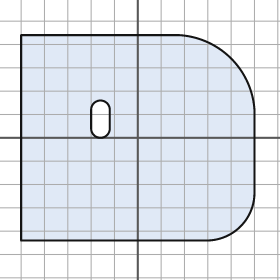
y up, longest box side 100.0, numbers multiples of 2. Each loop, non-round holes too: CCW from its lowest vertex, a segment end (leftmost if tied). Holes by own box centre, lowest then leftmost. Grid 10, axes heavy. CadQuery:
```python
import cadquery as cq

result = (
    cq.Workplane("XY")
    .moveTo(-50.0, -44.0)
    .lineTo(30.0, -44.0)
    .threePointArc((44.0, -38.0), (50.0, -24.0))
    .lineTo(50.0, 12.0)
    .threePointArc((40.0, 34.0), (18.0, 44.0))
    .lineTo(-50.0, 44.0)
    .close()
    .moveTo(-20.0, 4.0)
    .threePointArc((-16.0, 0.0), (-12.0, 4.0))
    .lineTo(-12.0, 12.0)
    .threePointArc((-16.0, 16.0), (-20.0, 12.0))
    .close()
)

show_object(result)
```